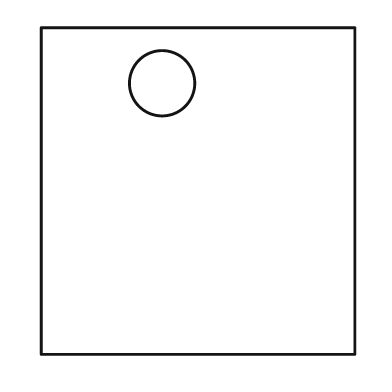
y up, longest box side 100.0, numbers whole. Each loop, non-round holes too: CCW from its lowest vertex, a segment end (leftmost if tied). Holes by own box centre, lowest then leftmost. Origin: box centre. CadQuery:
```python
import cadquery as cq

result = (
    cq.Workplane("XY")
    .moveTo(-48.0, -50.0)
    .lineTo(48.0, -50.0)
    .lineTo(48.0, 50.0)
    .lineTo(-48.0, 50.0)
    .close()
    .moveTo(-11.0, 33.0)
    .circle(10.0)
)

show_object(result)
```